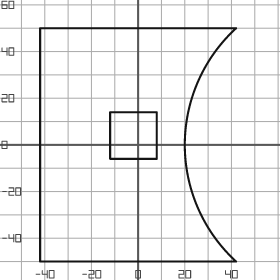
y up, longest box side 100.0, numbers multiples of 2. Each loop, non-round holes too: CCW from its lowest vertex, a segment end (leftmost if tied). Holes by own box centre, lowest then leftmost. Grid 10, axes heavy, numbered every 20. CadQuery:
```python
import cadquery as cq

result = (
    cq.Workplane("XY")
    .moveTo(-42.0, -50.0)
    .lineTo(42.0, -50.0)
    .threePointArc((20.0, 0.0), (42.0, 50.0))
    .lineTo(-42.0, 50.0)
    .close()
    .moveTo(-12.0, -6.0)
    .lineTo(8.0, -6.0)
    .lineTo(8.0, 14.0)
    .lineTo(-12.0, 14.0)
    .close()
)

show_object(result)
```